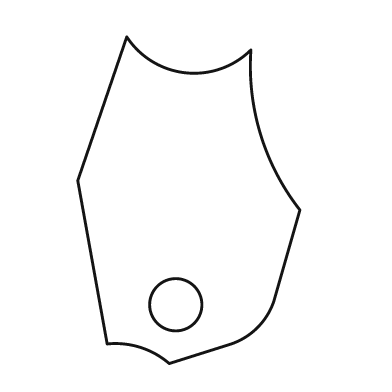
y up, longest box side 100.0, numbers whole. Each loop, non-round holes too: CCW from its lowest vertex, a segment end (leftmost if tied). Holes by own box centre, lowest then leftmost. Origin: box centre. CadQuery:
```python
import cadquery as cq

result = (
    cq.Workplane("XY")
    .moveTo(-6.0, -50.0)
    .lineTo(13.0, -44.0)
    .threePointArc((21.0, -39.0), (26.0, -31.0))
    .lineTo(34.0, -3.0)
    .threePointArc((22.0, 20.0), (19.0, 46.0))
    .threePointArc((-1.0, 39.0), (-19.0, 50.0))
    .lineTo(-34.0, 6.0)
    .lineTo(-25.0, -44.0)
    .threePointArc((-15.0, -45.0), (-6.0, -50.0))
    .close()
    .moveTo(-4.0, -32.0)
    .circle(8.0)
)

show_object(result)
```